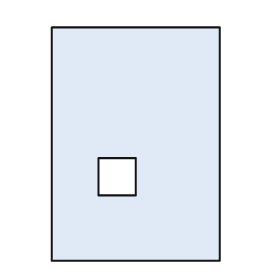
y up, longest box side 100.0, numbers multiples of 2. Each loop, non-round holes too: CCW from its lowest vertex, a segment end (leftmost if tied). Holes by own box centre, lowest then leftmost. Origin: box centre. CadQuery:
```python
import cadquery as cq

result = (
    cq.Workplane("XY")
    .moveTo(-36.0, -50.0)
    .lineTo(36.0, -50.0)
    .lineTo(36.0, 50.0)
    .lineTo(-36.0, 50.0)
    .close()
    .moveTo(-16.0, -22.0)
    .lineTo(0.0, -22.0)
    .lineTo(0.0, -6.0)
    .lineTo(-16.0, -6.0)
    .close()
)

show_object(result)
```